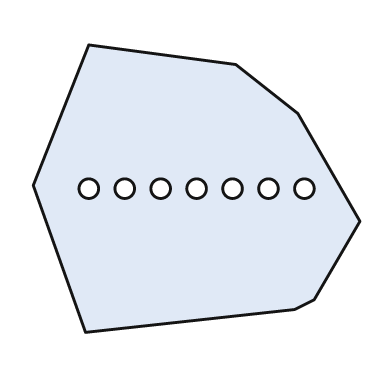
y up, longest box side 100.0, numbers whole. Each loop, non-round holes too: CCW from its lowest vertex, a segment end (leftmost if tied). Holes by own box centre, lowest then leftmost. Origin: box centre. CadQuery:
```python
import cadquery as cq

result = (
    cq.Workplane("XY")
    .moveTo(-34.0, -44.0)
    .lineTo(30.0, -37.0)
    .lineTo(36.0, -34.0)
    .lineTo(50.0, -10.0)
    .lineTo(31.0, 23.0)
    .lineTo(12.0, 38.0)
    .lineTo(-33.0, 44.0)
    .lineTo(-50.0, 1.0)
    .close()
    .moveTo(-33.0, 0.0)
    .circle(3.0)
    .moveTo(-22.0, 0.0)
    .circle(3.0)
    .moveTo(-11.0, 0.0)
    .circle(3.0)
    .moveTo(0.0, 0.0)
    .circle(3.0)
    .moveTo(11.0, 0.0)
    .circle(3.0)
    .moveTo(22.0, 0.0)
    .circle(3.0)
    .moveTo(33.0, 0.0)
    .circle(3.0)
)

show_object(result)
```